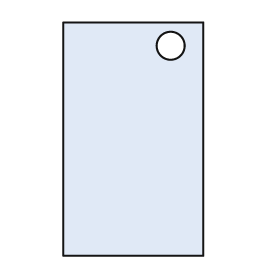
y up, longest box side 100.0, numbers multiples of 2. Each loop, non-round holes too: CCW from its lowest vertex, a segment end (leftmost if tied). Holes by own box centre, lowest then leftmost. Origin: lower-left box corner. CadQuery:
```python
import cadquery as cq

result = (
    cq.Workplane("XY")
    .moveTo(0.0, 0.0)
    .lineTo(60.0, 0.0)
    .lineTo(60.0, 100.0)
    .lineTo(0.0, 100.0)
    .close()
    .moveTo(46.0, 90.0)
    .circle(6.0)
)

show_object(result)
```